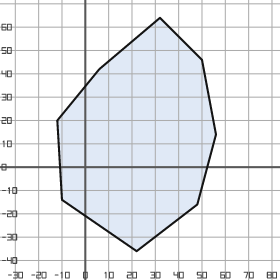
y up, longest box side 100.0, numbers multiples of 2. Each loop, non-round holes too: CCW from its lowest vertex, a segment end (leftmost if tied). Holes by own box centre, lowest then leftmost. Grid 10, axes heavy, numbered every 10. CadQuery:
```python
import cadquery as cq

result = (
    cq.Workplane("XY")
    .moveTo(22.0, -36.0)
    .lineTo(48.0, -16.0)
    .lineTo(56.0, 14.0)
    .lineTo(50.0, 46.0)
    .lineTo(32.0, 64.0)
    .lineTo(6.0, 42.0)
    .lineTo(-12.0, 20.0)
    .lineTo(-10.0, -14.0)
    .close()
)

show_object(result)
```